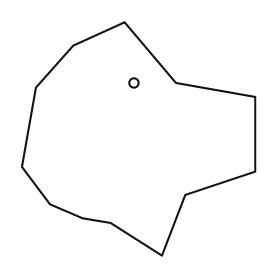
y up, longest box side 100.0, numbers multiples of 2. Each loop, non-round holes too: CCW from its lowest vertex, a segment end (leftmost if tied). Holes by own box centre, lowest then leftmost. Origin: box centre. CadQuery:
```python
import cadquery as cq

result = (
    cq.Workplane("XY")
    .moveTo(10.0, -50.0)
    .lineTo(20.0, -24.0)
    .lineTo(50.0, -14.0)
    .lineTo(50.0, 18.0)
    .lineTo(16.0, 24.0)
    .lineTo(-6.0, 50.0)
    .lineTo(-28.0, 40.0)
    .lineTo(-44.0, 22.0)
    .lineTo(-50.0, -12.0)
    .lineTo(-38.0, -28.0)
    .lineTo(-24.0, -34.0)
    .lineTo(-12.0, -36.0)
    .close()
    .moveTo(-2.0, 24.0)
    .circle(2.0)
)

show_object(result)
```